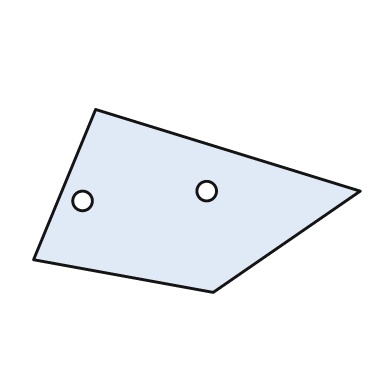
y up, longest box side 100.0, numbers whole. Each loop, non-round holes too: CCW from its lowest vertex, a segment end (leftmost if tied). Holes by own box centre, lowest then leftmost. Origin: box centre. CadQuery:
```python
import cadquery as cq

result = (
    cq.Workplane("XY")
    .moveTo(5.0, -28.0)
    .lineTo(50.0, 3.0)
    .lineTo(-31.0, 28.0)
    .lineTo(-50.0, -18.0)
    .close()
    .moveTo(-35.0, 0.0)
    .circle(3.0)
    .moveTo(3.0, 3.0)
    .circle(3.0)
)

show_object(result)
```